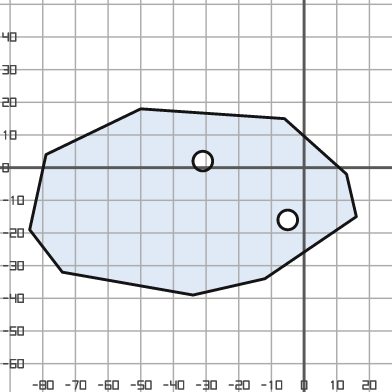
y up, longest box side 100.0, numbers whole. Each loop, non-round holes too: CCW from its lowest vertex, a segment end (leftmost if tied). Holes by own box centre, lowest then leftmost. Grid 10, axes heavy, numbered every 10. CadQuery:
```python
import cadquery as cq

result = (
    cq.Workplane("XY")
    .moveTo(-34.0, -39.0)
    .lineTo(-12.0, -34.0)
    .lineTo(16.0, -15.0)
    .lineTo(13.0, -2.0)
    .lineTo(-6.0, 15.0)
    .lineTo(-50.0, 18.0)
    .lineTo(-79.0, 4.0)
    .lineTo(-84.0, -19.0)
    .lineTo(-74.0, -32.0)
    .close()
    .moveTo(-5.0, -16.0)
    .circle(3.0)
    .moveTo(-31.0, 2.0)
    .circle(3.0)
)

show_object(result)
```